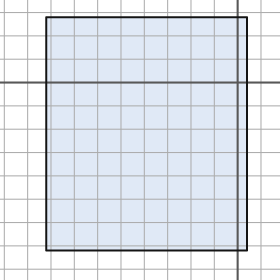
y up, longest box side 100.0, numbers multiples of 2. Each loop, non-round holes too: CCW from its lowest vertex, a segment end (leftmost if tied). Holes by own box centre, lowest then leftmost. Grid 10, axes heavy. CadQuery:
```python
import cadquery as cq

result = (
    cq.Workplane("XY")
    .moveTo(-82.0, -72.0)
    .lineTo(4.0, -72.0)
    .lineTo(4.0, 28.0)
    .lineTo(-82.0, 28.0)
    .close()
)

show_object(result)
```